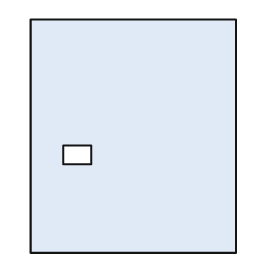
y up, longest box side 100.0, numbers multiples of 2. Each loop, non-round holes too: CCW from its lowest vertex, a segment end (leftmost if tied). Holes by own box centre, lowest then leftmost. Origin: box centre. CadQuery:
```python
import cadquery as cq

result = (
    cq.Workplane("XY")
    .moveTo(-44.0, -50.0)
    .lineTo(44.0, -50.0)
    .lineTo(44.0, 50.0)
    .lineTo(-44.0, 50.0)
    .close()
    .moveTo(-30.0, -12.0)
    .lineTo(-18.0, -12.0)
    .lineTo(-18.0, -4.0)
    .lineTo(-30.0, -4.0)
    .close()
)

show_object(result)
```